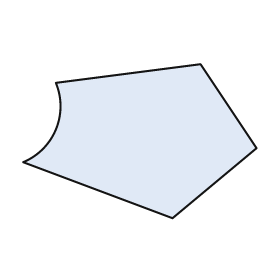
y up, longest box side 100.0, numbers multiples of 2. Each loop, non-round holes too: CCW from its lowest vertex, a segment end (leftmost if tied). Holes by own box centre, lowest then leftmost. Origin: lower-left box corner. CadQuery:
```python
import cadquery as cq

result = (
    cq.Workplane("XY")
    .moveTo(64.0, 0.0)
    .lineTo(100.0, 30.0)
    .lineTo(76.0, 66.0)
    .lineTo(14.0, 58.0)
    .threePointArc((14.0, 38.0), (0.0, 24.0))
    .close()
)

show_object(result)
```